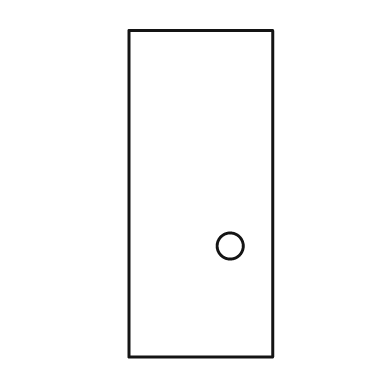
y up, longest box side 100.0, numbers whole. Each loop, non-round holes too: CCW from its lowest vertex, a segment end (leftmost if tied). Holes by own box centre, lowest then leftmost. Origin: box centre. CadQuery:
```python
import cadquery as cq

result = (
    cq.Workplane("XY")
    .moveTo(-22.0, -50.0)
    .lineTo(22.0, -50.0)
    .lineTo(22.0, 50.0)
    .lineTo(-22.0, 50.0)
    .close()
    .moveTo(9.0, -16.0)
    .circle(4.0)
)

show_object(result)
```